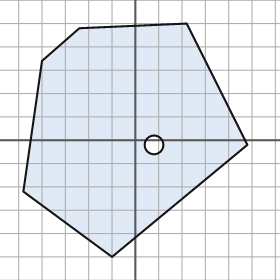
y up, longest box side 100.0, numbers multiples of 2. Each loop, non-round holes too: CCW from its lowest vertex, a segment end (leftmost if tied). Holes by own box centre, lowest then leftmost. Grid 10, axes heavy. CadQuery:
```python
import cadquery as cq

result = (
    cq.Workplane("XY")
    .moveTo(-10.0, -50.0)
    .lineTo(48.0, -2.0)
    .lineTo(22.0, 50.0)
    .lineTo(-24.0, 48.0)
    .lineTo(-40.0, 34.0)
    .lineTo(-48.0, -22.0)
    .close()
    .moveTo(8.0, -2.0)
    .circle(4.0)
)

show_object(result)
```